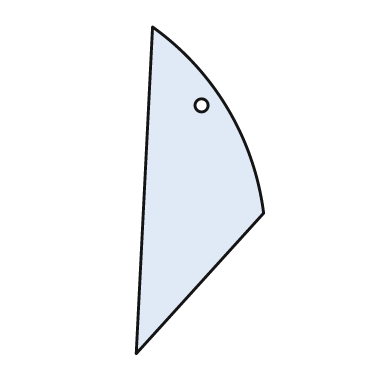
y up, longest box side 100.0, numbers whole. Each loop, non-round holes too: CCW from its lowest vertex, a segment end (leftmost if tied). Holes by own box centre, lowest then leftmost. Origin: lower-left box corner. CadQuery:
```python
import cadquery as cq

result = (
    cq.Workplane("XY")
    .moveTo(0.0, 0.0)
    .lineTo(39.0, 43.0)
    .threePointArc((28.0, 75.0), (5.0, 100.0))
    .close()
    .moveTo(20.0, 76.0)
    .circle(2.0)
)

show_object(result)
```